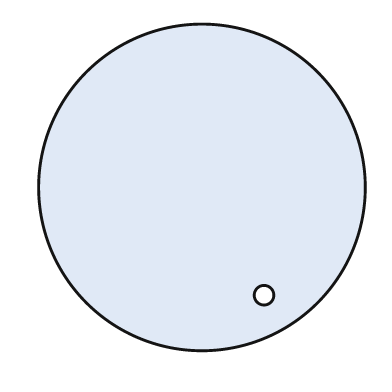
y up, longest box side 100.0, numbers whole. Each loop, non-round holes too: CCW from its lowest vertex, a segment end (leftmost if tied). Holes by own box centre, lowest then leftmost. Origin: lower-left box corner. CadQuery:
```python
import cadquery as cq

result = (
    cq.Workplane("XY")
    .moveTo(50.0, 50.0)
    .circle(50.0)
    .moveTo(69.0, 17.0)
    .circle(3.0)
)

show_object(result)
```